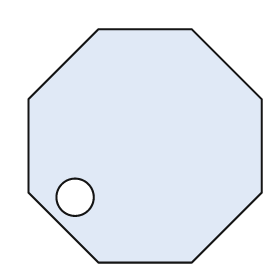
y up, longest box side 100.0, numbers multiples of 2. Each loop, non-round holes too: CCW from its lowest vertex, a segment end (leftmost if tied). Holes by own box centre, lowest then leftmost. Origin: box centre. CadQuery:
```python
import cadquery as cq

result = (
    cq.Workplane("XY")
    .moveTo(-20.0, -50.0)
    .lineTo(20.0, -50.0)
    .lineTo(50.0, -20.0)
    .lineTo(50.0, 20.0)
    .lineTo(20.0, 50.0)
    .lineTo(-20.0, 50.0)
    .lineTo(-50.0, 20.0)
    .lineTo(-50.0, -20.0)
    .close()
    .moveTo(-30.0, -22.0)
    .circle(8.0)
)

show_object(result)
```